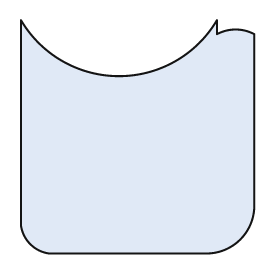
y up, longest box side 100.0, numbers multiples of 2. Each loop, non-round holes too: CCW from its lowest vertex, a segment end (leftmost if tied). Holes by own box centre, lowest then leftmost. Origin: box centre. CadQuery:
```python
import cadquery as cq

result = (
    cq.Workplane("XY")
    .moveTo(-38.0, -50.0)
    .lineTo(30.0, -50.0)
    .threePointArc((44.0, -44.0), (50.0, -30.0))
    .lineTo(50.0, 44.0)
    .threePointArc((42.0, 46.0), (34.0, 44.0))
    .lineTo(34.0, 50.0)
    .threePointArc((-8.0, 26.0), (-50.0, 50.0))
    .lineTo(-50.0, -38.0)
    .threePointArc((-46.0, -46.0), (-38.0, -50.0))
    .close()
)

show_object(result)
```